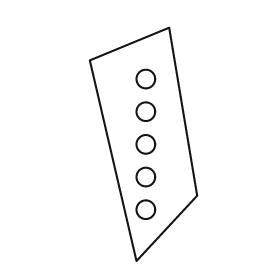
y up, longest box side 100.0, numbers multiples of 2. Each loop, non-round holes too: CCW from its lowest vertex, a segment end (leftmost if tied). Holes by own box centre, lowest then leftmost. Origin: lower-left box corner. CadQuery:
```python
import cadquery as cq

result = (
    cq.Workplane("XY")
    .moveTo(20.0, 0.0)
    .lineTo(46.0, 28.0)
    .lineTo(34.0, 100.0)
    .lineTo(0.0, 86.0)
    .close()
    .moveTo(24.0, 22.0)
    .circle(4.0)
    .moveTo(24.0, 36.0)
    .circle(4.0)
    .moveTo(24.0, 50.0)
    .circle(4.0)
    .moveTo(24.0, 64.0)
    .circle(4.0)
    .moveTo(24.0, 78.0)
    .circle(4.0)
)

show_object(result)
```